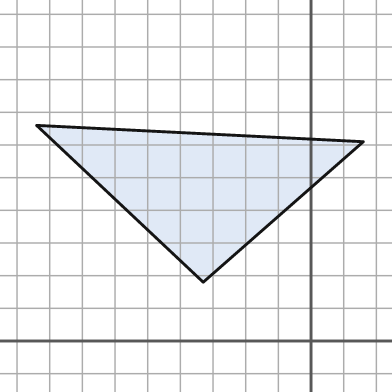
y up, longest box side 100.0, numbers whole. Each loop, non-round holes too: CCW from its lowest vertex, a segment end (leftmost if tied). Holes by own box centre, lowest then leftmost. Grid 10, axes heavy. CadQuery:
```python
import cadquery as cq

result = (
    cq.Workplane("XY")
    .moveTo(-33.0, 18.0)
    .lineTo(16.0, 61.0)
    .lineTo(-84.0, 66.0)
    .close()
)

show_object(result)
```